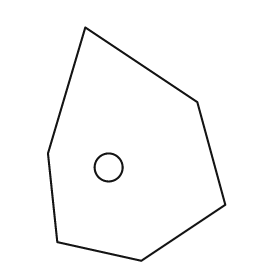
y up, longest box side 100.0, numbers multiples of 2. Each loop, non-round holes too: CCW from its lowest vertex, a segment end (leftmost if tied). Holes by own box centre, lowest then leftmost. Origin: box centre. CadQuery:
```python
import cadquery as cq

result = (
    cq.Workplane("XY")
    .moveTo(2.0, -50.0)
    .lineTo(38.0, -26.0)
    .lineTo(26.0, 18.0)
    .lineTo(-22.0, 50.0)
    .lineTo(-38.0, -4.0)
    .lineTo(-34.0, -42.0)
    .close()
    .moveTo(-12.0, -10.0)
    .circle(6.0)
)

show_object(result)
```